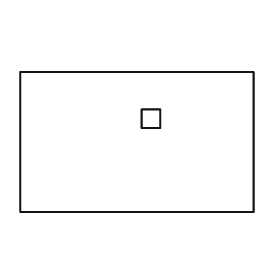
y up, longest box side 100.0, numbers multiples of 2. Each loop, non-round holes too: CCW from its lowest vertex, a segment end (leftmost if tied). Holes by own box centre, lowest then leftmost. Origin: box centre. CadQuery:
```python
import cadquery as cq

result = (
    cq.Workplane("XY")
    .moveTo(-50.0, -30.0)
    .lineTo(50.0, -30.0)
    .lineTo(50.0, 30.0)
    .lineTo(-50.0, 30.0)
    .close()
    .moveTo(2.0, 6.0)
    .lineTo(10.0, 6.0)
    .lineTo(10.0, 14.0)
    .lineTo(2.0, 14.0)
    .close()
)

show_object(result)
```